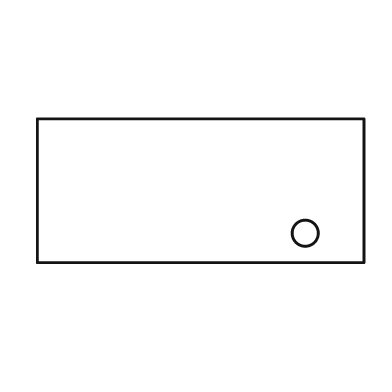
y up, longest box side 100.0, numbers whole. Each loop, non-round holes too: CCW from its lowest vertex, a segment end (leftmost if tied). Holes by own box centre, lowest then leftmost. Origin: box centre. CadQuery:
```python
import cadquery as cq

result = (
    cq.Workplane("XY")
    .moveTo(-50.0, -22.0)
    .lineTo(50.0, -22.0)
    .lineTo(50.0, 22.0)
    .lineTo(-50.0, 22.0)
    .close()
    .moveTo(32.0, -13.0)
    .circle(4.0)
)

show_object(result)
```